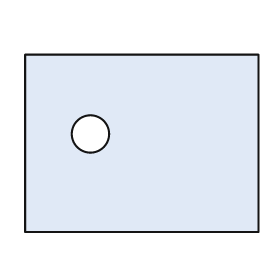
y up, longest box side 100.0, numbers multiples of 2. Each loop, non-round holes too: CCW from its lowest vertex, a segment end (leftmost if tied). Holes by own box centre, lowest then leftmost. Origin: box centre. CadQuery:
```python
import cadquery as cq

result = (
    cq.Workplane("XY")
    .moveTo(-50.0, -38.0)
    .lineTo(50.0, -38.0)
    .lineTo(50.0, 38.0)
    .lineTo(-50.0, 38.0)
    .close()
    .moveTo(-22.0, 4.0)
    .circle(8.0)
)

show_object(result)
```